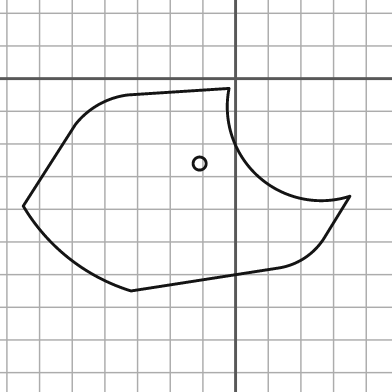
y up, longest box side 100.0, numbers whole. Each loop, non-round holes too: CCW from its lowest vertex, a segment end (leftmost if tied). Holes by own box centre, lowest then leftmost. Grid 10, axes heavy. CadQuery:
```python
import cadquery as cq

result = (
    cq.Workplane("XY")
    .moveTo(-32.0, -65.0)
    .lineTo(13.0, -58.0)
    .threePointArc((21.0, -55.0), (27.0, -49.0))
    .lineTo(35.0, -36.0)
    .threePointArc((7.0, -30.0), (-2.0, -3.0))
    .lineTo(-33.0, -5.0)
    .threePointArc((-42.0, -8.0), (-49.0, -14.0))
    .lineTo(-65.0, -39.0)
    .threePointArc((-51.0, -55.0), (-32.0, -65.0))
    .close()
    .moveTo(-11.0, -26.0)
    .circle(2.0)
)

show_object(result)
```